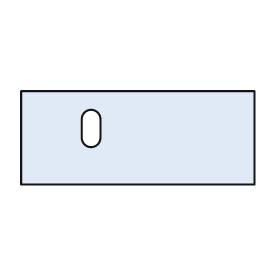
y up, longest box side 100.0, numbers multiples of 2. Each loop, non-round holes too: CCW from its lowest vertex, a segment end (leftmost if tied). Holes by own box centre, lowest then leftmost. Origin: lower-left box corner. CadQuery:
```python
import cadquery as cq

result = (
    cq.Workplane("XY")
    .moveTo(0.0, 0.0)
    .lineTo(100.0, 0.0)
    .lineTo(100.0, 40.0)
    .lineTo(0.0, 40.0)
    .close()
    .moveTo(26.0, 20.0)
    .threePointArc((30.0, 16.0), (34.0, 20.0))
    .lineTo(34.0, 28.0)
    .threePointArc((30.0, 32.0), (26.0, 28.0))
    .close()
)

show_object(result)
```